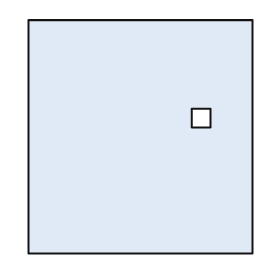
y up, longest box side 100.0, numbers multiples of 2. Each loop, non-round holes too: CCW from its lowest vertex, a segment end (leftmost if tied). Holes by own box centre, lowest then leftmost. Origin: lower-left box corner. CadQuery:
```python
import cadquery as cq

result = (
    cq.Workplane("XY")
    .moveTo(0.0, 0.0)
    .lineTo(96.0, 0.0)
    .lineTo(96.0, 100.0)
    .lineTo(0.0, 100.0)
    .close()
    .moveTo(70.0, 54.0)
    .lineTo(78.0, 54.0)
    .lineTo(78.0, 62.0)
    .lineTo(70.0, 62.0)
    .close()
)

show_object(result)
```